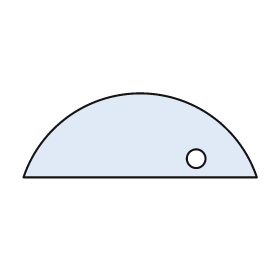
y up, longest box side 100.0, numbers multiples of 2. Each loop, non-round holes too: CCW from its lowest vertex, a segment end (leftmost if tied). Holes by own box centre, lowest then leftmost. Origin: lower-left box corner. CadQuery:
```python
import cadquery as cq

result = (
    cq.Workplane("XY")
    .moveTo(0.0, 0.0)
    .lineTo(100.0, 0.0)
    .threePointArc((50.0, 36.0), (0.0, 0.0))
    .close()
    .moveTo(74.0, 8.0)
    .circle(4.0)
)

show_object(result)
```